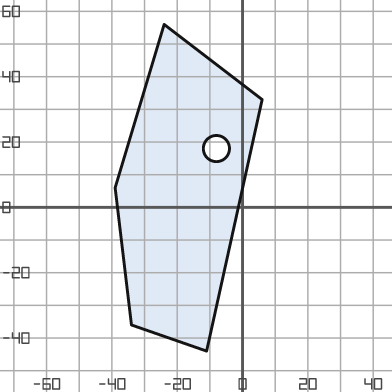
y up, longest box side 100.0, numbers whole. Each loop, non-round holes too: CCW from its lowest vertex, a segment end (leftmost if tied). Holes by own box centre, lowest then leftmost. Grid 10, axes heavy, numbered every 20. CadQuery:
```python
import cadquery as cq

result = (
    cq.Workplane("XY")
    .moveTo(-11.0, -44.0)
    .lineTo(6.0, 33.0)
    .lineTo(-24.0, 56.0)
    .lineTo(-39.0, 6.0)
    .lineTo(-34.0, -36.0)
    .close()
    .moveTo(-8.0, 18.0)
    .circle(4.0)
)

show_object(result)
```